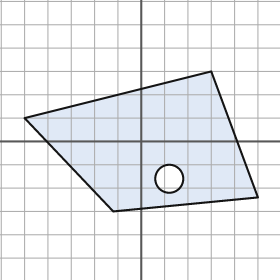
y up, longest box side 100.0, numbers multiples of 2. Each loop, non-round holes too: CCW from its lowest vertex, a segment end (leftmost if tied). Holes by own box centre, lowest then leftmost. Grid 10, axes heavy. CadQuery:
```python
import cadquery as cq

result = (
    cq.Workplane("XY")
    .moveTo(-12.0, -30.0)
    .lineTo(50.0, -24.0)
    .lineTo(30.0, 30.0)
    .lineTo(-50.0, 10.0)
    .close()
    .moveTo(12.0, -16.0)
    .circle(6.0)
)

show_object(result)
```